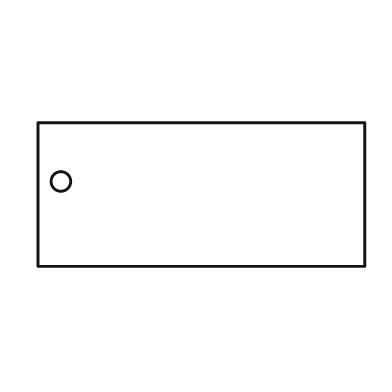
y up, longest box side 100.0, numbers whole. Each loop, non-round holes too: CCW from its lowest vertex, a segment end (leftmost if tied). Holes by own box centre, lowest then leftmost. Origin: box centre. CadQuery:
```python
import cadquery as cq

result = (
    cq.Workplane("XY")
    .moveTo(-50.0, -22.0)
    .lineTo(50.0, -22.0)
    .lineTo(50.0, 22.0)
    .lineTo(-50.0, 22.0)
    .close()
    .moveTo(-43.0, 4.0)
    .circle(3.0)
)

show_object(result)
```